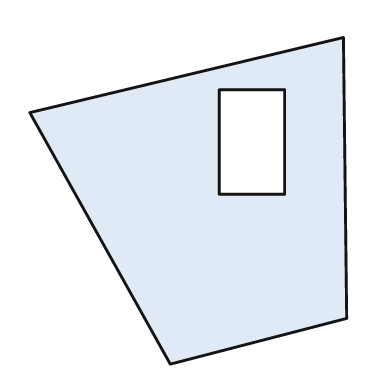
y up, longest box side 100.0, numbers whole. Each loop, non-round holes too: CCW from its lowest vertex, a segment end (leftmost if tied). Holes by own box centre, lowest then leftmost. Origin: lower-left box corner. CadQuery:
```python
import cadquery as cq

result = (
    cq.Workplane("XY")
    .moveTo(43.0, 0.0)
    .lineTo(97.0, 14.0)
    .lineTo(96.0, 100.0)
    .lineTo(0.0, 77.0)
    .close()
    .moveTo(58.0, 52.0)
    .lineTo(78.0, 52.0)
    .lineTo(78.0, 84.0)
    .lineTo(58.0, 84.0)
    .close()
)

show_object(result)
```